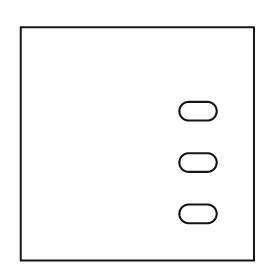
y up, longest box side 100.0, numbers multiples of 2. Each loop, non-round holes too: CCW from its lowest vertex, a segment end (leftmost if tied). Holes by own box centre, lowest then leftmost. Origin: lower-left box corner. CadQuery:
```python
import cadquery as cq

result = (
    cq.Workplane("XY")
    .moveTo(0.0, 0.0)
    .lineTo(100.0, 0.0)
    .lineTo(100.0, 100.0)
    .lineTo(0.0, 100.0)
    .close()
    .moveTo(72.0, 16.0)
    .lineTo(80.0, 16.0)
    .threePointArc((84.0, 20.0), (80.0, 24.0))
    .lineTo(72.0, 24.0)
    .threePointArc((68.0, 20.0), (72.0, 16.0))
    .close()
    .moveTo(72.0, 38.0)
    .lineTo(80.0, 38.0)
    .threePointArc((84.0, 42.0), (80.0, 46.0))
    .lineTo(72.0, 46.0)
    .threePointArc((68.0, 42.0), (72.0, 38.0))
    .close()
    .moveTo(72.0, 60.0)
    .lineTo(80.0, 60.0)
    .threePointArc((84.0, 64.0), (80.0, 68.0))
    .lineTo(72.0, 68.0)
    .threePointArc((68.0, 64.0), (72.0, 60.0))
    .close()
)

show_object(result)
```